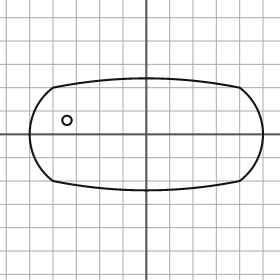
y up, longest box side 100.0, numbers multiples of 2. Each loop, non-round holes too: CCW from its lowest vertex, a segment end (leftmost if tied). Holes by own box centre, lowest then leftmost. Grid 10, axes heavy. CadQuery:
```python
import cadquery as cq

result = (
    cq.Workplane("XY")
    .moveTo(-40.0, -20.0)
    .threePointArc((0.0, -24.0), (40.0, -20.0))
    .threePointArc((50.0, 0.0), (40.0, 20.0))
    .threePointArc((0.0, 24.0), (-40.0, 20.0))
    .threePointArc((-50.0, 0.0), (-40.0, -20.0))
    .close()
    .moveTo(-34.0, 6.0)
    .circle(2.0)
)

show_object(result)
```